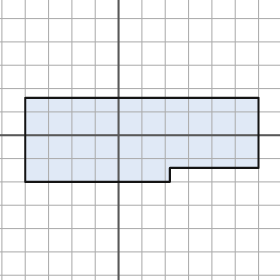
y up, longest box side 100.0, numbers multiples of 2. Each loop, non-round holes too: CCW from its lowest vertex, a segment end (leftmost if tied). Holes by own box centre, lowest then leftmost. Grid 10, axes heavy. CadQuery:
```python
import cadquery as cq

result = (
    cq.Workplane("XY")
    .moveTo(-40.0, -20.0)
    .lineTo(22.0, -20.0)
    .lineTo(22.0, -14.0)
    .lineTo(60.0, -14.0)
    .lineTo(60.0, 16.0)
    .lineTo(-40.0, 16.0)
    .close()
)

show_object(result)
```